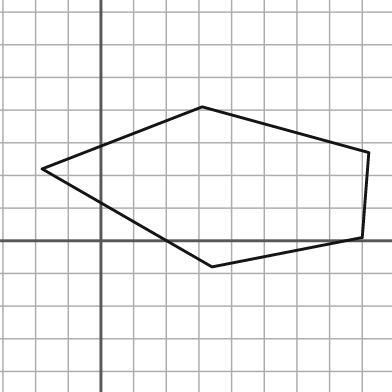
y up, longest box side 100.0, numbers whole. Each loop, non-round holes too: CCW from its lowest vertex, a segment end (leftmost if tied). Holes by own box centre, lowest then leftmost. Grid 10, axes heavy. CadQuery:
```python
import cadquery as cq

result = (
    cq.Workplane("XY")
    .moveTo(34.0, -8.0)
    .lineTo(80.0, 1.0)
    .lineTo(82.0, 27.0)
    .lineTo(31.0, 41.0)
    .lineTo(-18.0, 22.0)
    .close()
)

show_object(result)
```